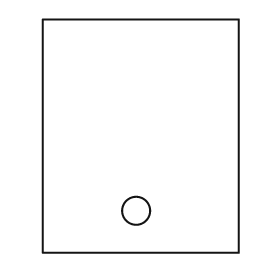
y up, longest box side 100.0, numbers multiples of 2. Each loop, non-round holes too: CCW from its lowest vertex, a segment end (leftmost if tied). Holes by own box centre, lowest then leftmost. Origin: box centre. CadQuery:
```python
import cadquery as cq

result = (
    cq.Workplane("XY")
    .moveTo(-42.0, -50.0)
    .lineTo(42.0, -50.0)
    .lineTo(42.0, 50.0)
    .lineTo(-42.0, 50.0)
    .close()
    .moveTo(-2.0, -32.0)
    .circle(6.0)
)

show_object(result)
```